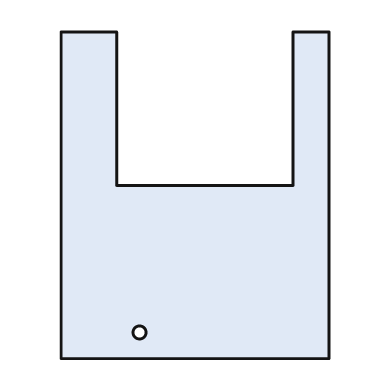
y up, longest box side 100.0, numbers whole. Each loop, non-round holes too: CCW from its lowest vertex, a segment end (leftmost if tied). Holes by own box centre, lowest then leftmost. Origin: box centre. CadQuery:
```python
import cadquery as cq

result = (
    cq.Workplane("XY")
    .moveTo(-41.0, -50.0)
    .lineTo(41.0, -50.0)
    .lineTo(41.0, 50.0)
    .lineTo(30.0, 50.0)
    .lineTo(30.0, 3.0)
    .lineTo(-24.0, 3.0)
    .lineTo(-24.0, 50.0)
    .lineTo(-41.0, 50.0)
    .close()
    .moveTo(-17.0, -42.0)
    .circle(2.0)
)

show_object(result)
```